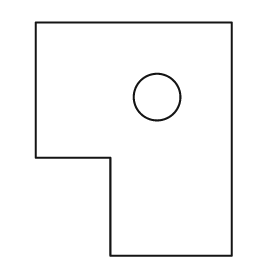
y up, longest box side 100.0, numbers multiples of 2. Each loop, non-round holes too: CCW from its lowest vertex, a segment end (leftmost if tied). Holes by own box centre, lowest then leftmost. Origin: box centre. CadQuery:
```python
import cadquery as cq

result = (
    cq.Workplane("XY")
    .moveTo(-10.0, -50.0)
    .lineTo(42.0, -50.0)
    .lineTo(42.0, 50.0)
    .lineTo(-42.0, 50.0)
    .lineTo(-42.0, -8.0)
    .lineTo(-10.0, -8.0)
    .close()
    .moveTo(10.0, 18.0)
    .circle(10.0)
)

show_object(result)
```